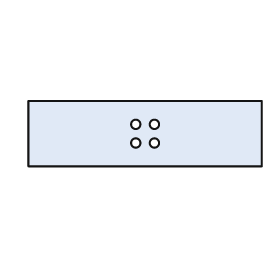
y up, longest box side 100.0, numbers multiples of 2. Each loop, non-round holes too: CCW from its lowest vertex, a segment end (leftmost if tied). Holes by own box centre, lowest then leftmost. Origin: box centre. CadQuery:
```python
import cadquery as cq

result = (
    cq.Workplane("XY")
    .moveTo(-50.0, -14.0)
    .lineTo(50.0, -14.0)
    .lineTo(50.0, 14.0)
    .lineTo(-50.0, 14.0)
    .close()
    .moveTo(-4.0, -4.0)
    .circle(2.0)
    .moveTo(4.0, -4.0)
    .circle(2.0)
    .moveTo(-4.0, 4.0)
    .circle(2.0)
    .moveTo(4.0, 4.0)
    .circle(2.0)
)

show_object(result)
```